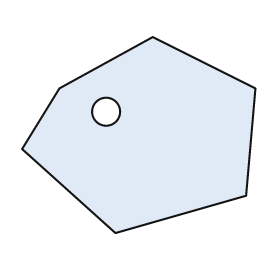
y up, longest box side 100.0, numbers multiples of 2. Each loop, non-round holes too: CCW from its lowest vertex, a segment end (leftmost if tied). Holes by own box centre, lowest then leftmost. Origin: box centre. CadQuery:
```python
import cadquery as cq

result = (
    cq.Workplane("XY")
    .moveTo(-10.0, -42.0)
    .lineTo(46.0, -26.0)
    .lineTo(50.0, 20.0)
    .lineTo(6.0, 42.0)
    .lineTo(-34.0, 20.0)
    .lineTo(-50.0, -6.0)
    .close()
    .moveTo(-14.0, 10.0)
    .circle(6.0)
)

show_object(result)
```